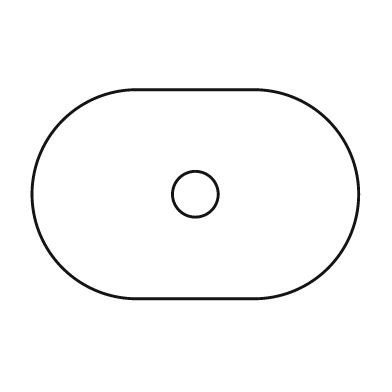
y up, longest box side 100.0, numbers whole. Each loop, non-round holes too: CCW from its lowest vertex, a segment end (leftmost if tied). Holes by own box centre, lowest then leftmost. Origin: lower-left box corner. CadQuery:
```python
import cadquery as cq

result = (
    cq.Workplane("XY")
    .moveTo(32.0, 0.0)
    .lineTo(68.0, 0.0)
    .threePointArc((100.0, 32.0), (68.0, 64.0))
    .lineTo(32.0, 64.0)
    .threePointArc((0.0, 32.0), (32.0, 0.0))
    .close()
    .moveTo(50.0, 32.0)
    .circle(7.0)
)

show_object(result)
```